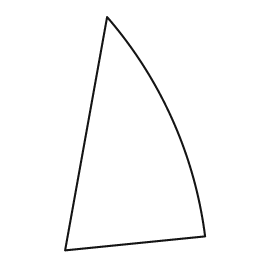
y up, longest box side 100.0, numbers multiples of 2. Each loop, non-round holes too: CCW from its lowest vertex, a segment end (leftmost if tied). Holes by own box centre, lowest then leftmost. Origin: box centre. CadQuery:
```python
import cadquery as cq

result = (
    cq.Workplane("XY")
    .moveTo(-30.0, -50.0)
    .lineTo(30.0, -44.0)
    .threePointArc((16.0, 6.0), (-12.0, 50.0))
    .close()
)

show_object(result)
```